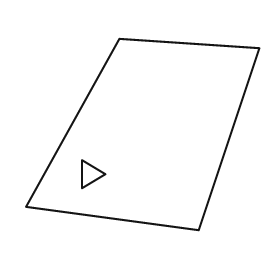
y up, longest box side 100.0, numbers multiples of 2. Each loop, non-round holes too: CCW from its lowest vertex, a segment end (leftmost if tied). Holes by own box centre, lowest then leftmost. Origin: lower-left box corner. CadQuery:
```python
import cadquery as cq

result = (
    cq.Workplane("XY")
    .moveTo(74.0, 0.0)
    .lineTo(100.0, 78.0)
    .lineTo(40.0, 82.0)
    .lineTo(0.0, 10.0)
    .close()
    .moveTo(24.0, 18.0)
    .lineTo(34.0, 24.0)
    .lineTo(24.0, 30.0)
    .close()
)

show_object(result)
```